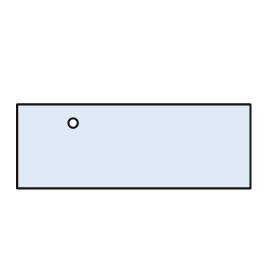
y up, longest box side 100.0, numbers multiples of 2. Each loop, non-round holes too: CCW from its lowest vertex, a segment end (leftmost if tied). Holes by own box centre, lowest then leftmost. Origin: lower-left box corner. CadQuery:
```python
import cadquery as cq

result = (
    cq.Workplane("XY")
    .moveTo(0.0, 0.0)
    .lineTo(100.0, 0.0)
    .lineTo(100.0, 36.0)
    .lineTo(0.0, 36.0)
    .close()
    .moveTo(24.0, 28.0)
    .circle(2.0)
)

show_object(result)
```